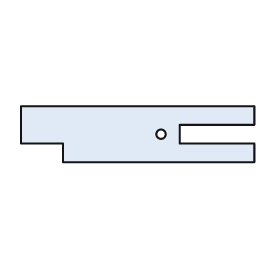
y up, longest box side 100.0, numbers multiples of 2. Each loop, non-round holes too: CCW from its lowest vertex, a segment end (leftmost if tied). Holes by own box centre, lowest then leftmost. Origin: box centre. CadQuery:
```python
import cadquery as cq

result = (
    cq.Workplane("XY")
    .moveTo(-32.0, -12.0)
    .lineTo(50.0, -12.0)
    .lineTo(50.0, -4.0)
    .lineTo(18.0, -4.0)
    .lineTo(18.0, 4.0)
    .lineTo(50.0, 4.0)
    .lineTo(50.0, 12.0)
    .lineTo(-50.0, 12.0)
    .lineTo(-50.0, -4.0)
    .lineTo(-32.0, -4.0)
    .close()
    .moveTo(10.0, 0.0)
    .circle(2.0)
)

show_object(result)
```